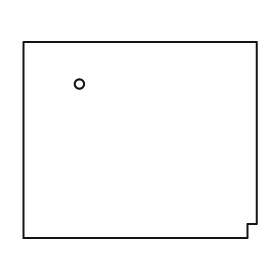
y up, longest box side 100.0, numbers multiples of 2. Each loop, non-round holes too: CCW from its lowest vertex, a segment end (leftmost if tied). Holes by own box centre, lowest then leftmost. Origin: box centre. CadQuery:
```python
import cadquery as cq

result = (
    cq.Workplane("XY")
    .moveTo(-50.0, -42.0)
    .lineTo(46.0, -42.0)
    .lineTo(46.0, -36.0)
    .lineTo(50.0, -36.0)
    .lineTo(50.0, 42.0)
    .lineTo(-50.0, 42.0)
    .close()
    .moveTo(-26.0, 24.0)
    .circle(2.0)
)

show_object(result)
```